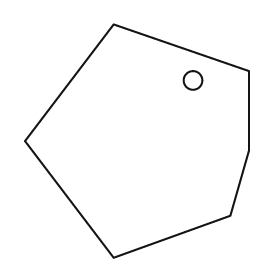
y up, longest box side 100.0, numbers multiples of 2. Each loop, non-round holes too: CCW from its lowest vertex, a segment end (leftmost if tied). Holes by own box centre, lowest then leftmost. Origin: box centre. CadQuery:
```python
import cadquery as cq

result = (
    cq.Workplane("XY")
    .moveTo(-10.0, -50.0)
    .lineTo(40.0, -32.0)
    .lineTo(48.0, -4.0)
    .lineTo(48.0, 30.0)
    .lineTo(-10.0, 50.0)
    .lineTo(-48.0, 0.0)
    .close()
    .moveTo(24.0, 26.0)
    .circle(4.0)
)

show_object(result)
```